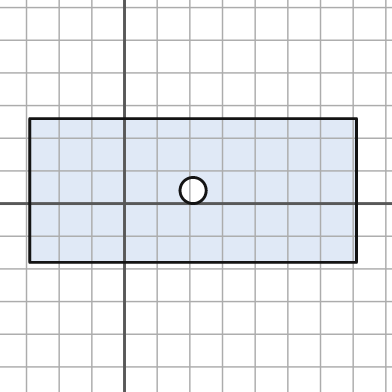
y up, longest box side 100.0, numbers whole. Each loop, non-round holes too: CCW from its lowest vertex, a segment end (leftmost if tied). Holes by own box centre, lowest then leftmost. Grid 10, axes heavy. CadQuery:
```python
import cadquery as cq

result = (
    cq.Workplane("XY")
    .moveTo(-29.0, -18.0)
    .lineTo(71.0, -18.0)
    .lineTo(71.0, 26.0)
    .lineTo(-29.0, 26.0)
    .close()
    .moveTo(21.0, 4.0)
    .circle(4.0)
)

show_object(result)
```